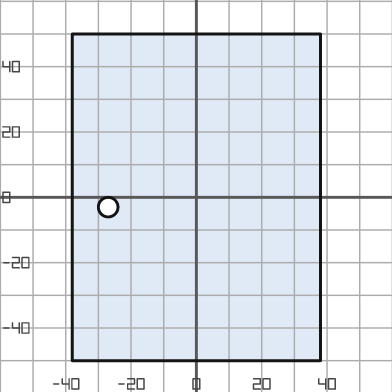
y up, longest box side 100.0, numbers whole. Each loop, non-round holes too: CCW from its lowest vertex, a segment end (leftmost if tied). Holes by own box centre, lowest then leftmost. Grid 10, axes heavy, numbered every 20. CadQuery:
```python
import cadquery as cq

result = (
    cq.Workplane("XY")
    .moveTo(-38.0, -50.0)
    .lineTo(38.0, -50.0)
    .lineTo(38.0, 50.0)
    .lineTo(-38.0, 50.0)
    .close()
    .moveTo(-27.0, -3.0)
    .circle(3.0)
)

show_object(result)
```